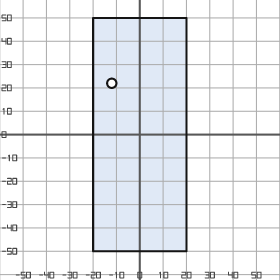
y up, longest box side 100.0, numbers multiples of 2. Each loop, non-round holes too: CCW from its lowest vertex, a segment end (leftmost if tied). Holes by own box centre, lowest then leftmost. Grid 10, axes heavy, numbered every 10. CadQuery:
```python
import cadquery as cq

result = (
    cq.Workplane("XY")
    .moveTo(-20.0, -50.0)
    .lineTo(20.0, -50.0)
    .lineTo(20.0, 50.0)
    .lineTo(-20.0, 50.0)
    .close()
    .moveTo(-12.0, 22.0)
    .circle(2.0)
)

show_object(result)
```